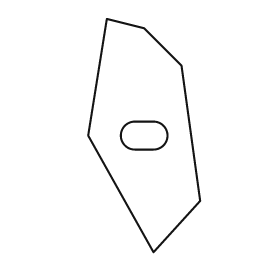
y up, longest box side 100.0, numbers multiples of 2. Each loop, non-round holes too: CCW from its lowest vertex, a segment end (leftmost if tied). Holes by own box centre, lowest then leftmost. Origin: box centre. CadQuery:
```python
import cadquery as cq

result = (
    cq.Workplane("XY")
    .moveTo(4.0, -50.0)
    .lineTo(24.0, -28.0)
    .lineTo(16.0, 30.0)
    .lineTo(0.0, 46.0)
    .lineTo(-16.0, 50.0)
    .lineTo(-24.0, 0.0)
    .close()
    .moveTo(-4.0, -6.0)
    .lineTo(4.0, -6.0)
    .threePointArc((10.0, 0.0), (4.0, 6.0))
    .lineTo(-4.0, 6.0)
    .threePointArc((-10.0, 0.0), (-4.0, -6.0))
    .close()
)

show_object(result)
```